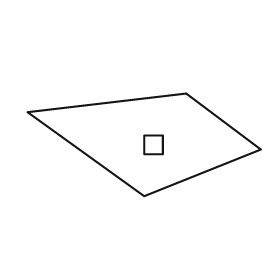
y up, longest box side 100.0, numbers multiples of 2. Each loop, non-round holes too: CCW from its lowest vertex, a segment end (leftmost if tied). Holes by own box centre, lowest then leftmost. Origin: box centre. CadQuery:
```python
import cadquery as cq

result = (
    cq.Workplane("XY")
    .moveTo(0.0, -22.0)
    .lineTo(50.0, -2.0)
    .lineTo(18.0, 22.0)
    .lineTo(-50.0, 14.0)
    .close()
    .moveTo(0.0, -4.0)
    .lineTo(8.0, -4.0)
    .lineTo(8.0, 4.0)
    .lineTo(0.0, 4.0)
    .close()
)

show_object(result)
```